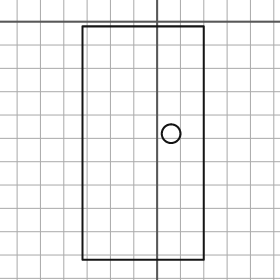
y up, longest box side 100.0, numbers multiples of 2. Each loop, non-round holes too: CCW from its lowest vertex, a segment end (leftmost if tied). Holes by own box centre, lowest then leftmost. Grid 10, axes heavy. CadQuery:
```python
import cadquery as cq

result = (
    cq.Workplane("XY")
    .moveTo(-32.0, -102.0)
    .lineTo(20.0, -102.0)
    .lineTo(20.0, -2.0)
    .lineTo(-32.0, -2.0)
    .close()
    .moveTo(6.0, -48.0)
    .circle(4.0)
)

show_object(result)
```